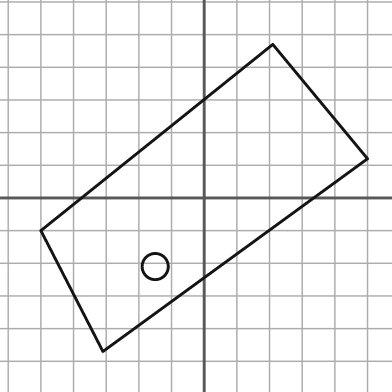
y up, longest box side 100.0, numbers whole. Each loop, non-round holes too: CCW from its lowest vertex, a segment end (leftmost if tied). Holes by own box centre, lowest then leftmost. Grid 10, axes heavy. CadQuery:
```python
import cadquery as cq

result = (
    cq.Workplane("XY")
    .moveTo(-31.0, -47.0)
    .lineTo(50.0, 12.0)
    .lineTo(21.0, 47.0)
    .lineTo(-50.0, -10.0)
    .close()
    .moveTo(-15.0, -21.0)
    .circle(4.0)
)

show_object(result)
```